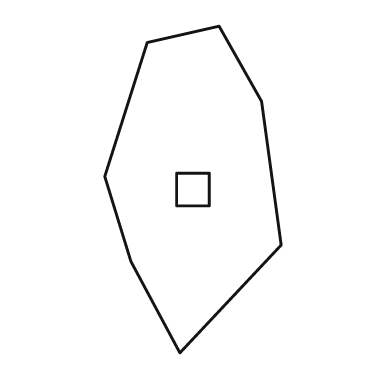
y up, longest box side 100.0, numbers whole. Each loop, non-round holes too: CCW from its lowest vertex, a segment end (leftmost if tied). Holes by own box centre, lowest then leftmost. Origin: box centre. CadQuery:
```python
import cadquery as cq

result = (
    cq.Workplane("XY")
    .moveTo(-4.0, -50.0)
    .lineTo(27.0, -17.0)
    .lineTo(21.0, 27.0)
    .lineTo(8.0, 50.0)
    .lineTo(-14.0, 45.0)
    .lineTo(-27.0, 4.0)
    .lineTo(-19.0, -22.0)
    .close()
    .moveTo(-5.0, -5.0)
    .lineTo(5.0, -5.0)
    .lineTo(5.0, 5.0)
    .lineTo(-5.0, 5.0)
    .close()
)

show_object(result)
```